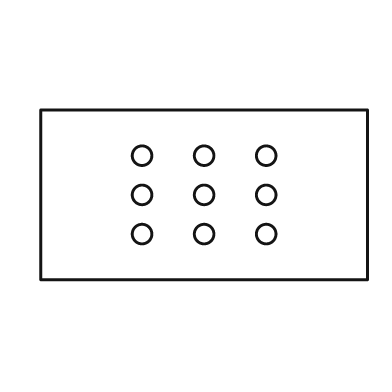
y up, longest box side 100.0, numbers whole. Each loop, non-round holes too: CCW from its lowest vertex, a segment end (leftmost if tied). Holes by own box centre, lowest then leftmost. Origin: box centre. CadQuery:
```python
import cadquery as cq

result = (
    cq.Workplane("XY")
    .moveTo(-50.0, -26.0)
    .lineTo(50.0, -26.0)
    .lineTo(50.0, 26.0)
    .lineTo(-50.0, 26.0)
    .close()
    .moveTo(-19.0, -12.0)
    .circle(3.0)
    .moveTo(0.0, -12.0)
    .circle(3.0)
    .moveTo(19.0, -12.0)
    .circle(3.0)
    .moveTo(-19.0, 0.0)
    .circle(3.0)
    .moveTo(0.0, 0.0)
    .circle(3.0)
    .moveTo(19.0, 0.0)
    .circle(3.0)
    .moveTo(-19.0, 12.0)
    .circle(3.0)
    .moveTo(0.0, 12.0)
    .circle(3.0)
    .moveTo(19.0, 12.0)
    .circle(3.0)
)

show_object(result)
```